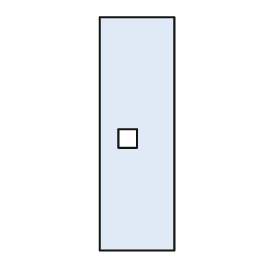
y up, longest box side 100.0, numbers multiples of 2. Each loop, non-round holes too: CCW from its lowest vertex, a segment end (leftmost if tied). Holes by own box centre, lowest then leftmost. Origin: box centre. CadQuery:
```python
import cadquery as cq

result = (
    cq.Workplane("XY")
    .moveTo(-16.0, -50.0)
    .lineTo(16.0, -50.0)
    .lineTo(16.0, 50.0)
    .lineTo(-16.0, 50.0)
    .close()
    .moveTo(-8.0, -6.0)
    .lineTo(0.0, -6.0)
    .lineTo(0.0, 2.0)
    .lineTo(-8.0, 2.0)
    .close()
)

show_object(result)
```